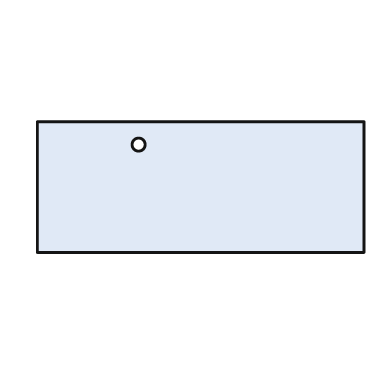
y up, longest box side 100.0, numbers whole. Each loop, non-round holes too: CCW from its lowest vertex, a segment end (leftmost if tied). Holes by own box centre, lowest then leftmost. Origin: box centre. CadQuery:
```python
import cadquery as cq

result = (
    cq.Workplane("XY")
    .moveTo(-50.0, -20.0)
    .lineTo(50.0, -20.0)
    .lineTo(50.0, 20.0)
    .lineTo(-50.0, 20.0)
    .close()
    .moveTo(-19.0, 13.0)
    .circle(2.0)
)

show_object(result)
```